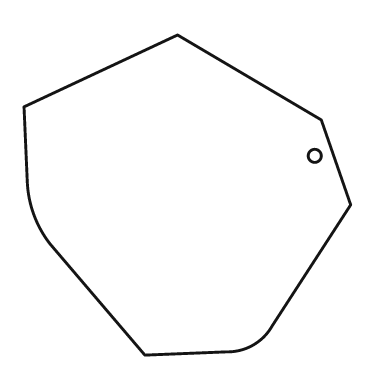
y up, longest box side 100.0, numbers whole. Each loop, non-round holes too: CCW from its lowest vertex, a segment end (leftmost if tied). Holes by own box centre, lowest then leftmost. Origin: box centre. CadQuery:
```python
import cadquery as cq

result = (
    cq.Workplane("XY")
    .moveTo(-13.0, -49.0)
    .lineTo(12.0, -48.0)
    .threePointArc((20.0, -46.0), (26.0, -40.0))
    .lineTo(50.0, -3.0)
    .lineTo(41.0, 23.0)
    .lineTo(-3.0, 49.0)
    .lineTo(-50.0, 27.0)
    .lineTo(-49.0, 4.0)
    .threePointArc((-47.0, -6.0), (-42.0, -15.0))
    .close()
    .moveTo(39.0, 12.0)
    .circle(2.0)
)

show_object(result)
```